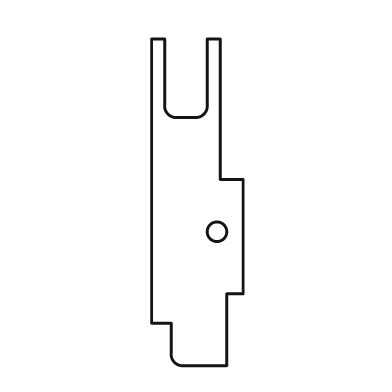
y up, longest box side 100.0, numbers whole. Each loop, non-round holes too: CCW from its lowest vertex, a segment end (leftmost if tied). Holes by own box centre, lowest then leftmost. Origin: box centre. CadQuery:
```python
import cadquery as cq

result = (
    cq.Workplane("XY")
    .moveTo(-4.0, -50.0)
    .lineTo(9.0, -50.0)
    .lineTo(9.0, -28.0)
    .lineTo(14.0, -28.0)
    .lineTo(14.0, 7.0)
    .lineTo(7.0, 7.0)
    .lineTo(7.0, 50.0)
    .lineTo(3.0, 50.0)
    .lineTo(3.0, 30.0)
    .threePointArc((2.0, 27.0), (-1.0, 26.0))
    .lineTo(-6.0, 26.0)
    .threePointArc((-9.0, 27.0), (-10.0, 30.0))
    .lineTo(-10.0, 50.0)
    .lineTo(-14.0, 50.0)
    .lineTo(-14.0, -37.0)
    .lineTo(-8.0, -37.0)
    .lineTo(-8.0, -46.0)
    .threePointArc((-7.0, -49.0), (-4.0, -50.0))
    .close()
    .moveTo(6.0, -9.0)
    .circle(3.0)
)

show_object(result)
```